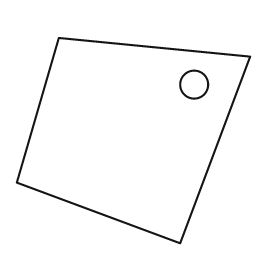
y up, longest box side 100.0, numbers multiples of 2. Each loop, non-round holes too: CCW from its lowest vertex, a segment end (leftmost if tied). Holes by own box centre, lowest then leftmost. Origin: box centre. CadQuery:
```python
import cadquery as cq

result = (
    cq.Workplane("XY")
    .moveTo(20.0, -44.0)
    .lineTo(50.0, 36.0)
    .lineTo(-32.0, 44.0)
    .lineTo(-50.0, -18.0)
    .close()
    .moveTo(26.0, 24.0)
    .circle(6.0)
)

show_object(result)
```